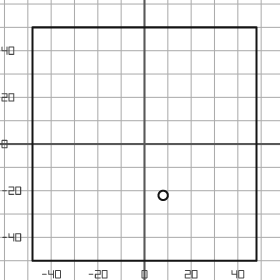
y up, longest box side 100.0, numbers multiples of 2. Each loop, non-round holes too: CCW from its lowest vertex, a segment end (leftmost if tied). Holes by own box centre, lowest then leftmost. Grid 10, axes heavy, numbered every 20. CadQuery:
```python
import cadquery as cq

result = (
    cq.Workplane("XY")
    .moveTo(-48.0, -50.0)
    .lineTo(48.0, -50.0)
    .lineTo(48.0, 50.0)
    .lineTo(-48.0, 50.0)
    .close()
    .moveTo(8.0, -22.0)
    .circle(2.0)
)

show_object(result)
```